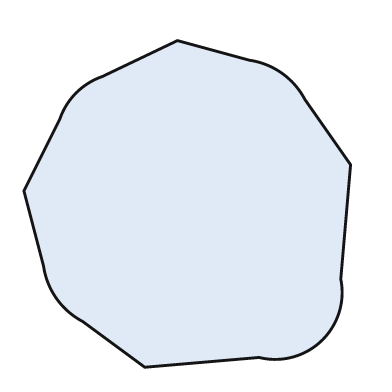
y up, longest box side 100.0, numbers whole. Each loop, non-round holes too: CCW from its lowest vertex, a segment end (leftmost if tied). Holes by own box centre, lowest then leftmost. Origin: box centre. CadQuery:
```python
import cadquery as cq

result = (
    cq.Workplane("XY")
    .moveTo(-13.0, -50.0)
    .lineTo(22.0, -47.0)
    .threePointArc((41.0, -42.0), (47.0, -23.0))
    .lineTo(50.0, 12.0)
    .lineTo(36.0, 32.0)
    .threePointArc((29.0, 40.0), (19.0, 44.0))
    .lineTo(-3.0, 50.0)
    .lineTo(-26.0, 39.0)
    .threePointArc((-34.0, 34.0), (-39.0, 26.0))
    .lineTo(-50.0, 4.0)
    .lineTo(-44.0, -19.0)
    .threePointArc((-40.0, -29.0), (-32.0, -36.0))
    .close()
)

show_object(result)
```